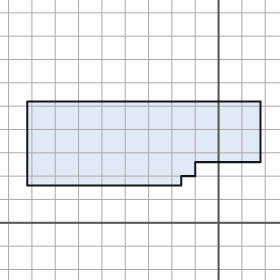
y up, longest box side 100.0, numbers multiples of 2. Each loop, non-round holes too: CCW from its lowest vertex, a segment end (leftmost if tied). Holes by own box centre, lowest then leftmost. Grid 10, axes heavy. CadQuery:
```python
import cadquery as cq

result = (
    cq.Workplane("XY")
    .moveTo(-82.0, 16.0)
    .lineTo(-16.0, 16.0)
    .lineTo(-16.0, 20.0)
    .lineTo(-10.0, 20.0)
    .lineTo(-10.0, 26.0)
    .lineTo(18.0, 26.0)
    .lineTo(18.0, 52.0)
    .lineTo(-82.0, 52.0)
    .close()
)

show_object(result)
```